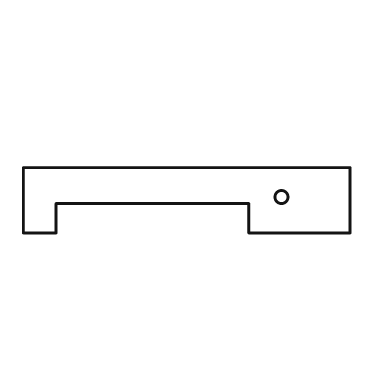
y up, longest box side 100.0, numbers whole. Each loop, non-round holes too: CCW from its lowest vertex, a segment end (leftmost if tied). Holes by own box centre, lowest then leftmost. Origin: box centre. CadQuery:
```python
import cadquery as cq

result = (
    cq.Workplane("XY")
    .moveTo(-50.0, -10.0)
    .lineTo(-40.0, -10.0)
    .lineTo(-40.0, -1.0)
    .lineTo(19.0, -1.0)
    .lineTo(19.0, -10.0)
    .lineTo(50.0, -10.0)
    .lineTo(50.0, 10.0)
    .lineTo(-50.0, 10.0)
    .close()
    .moveTo(29.0, 1.0)
    .circle(2.0)
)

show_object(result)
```